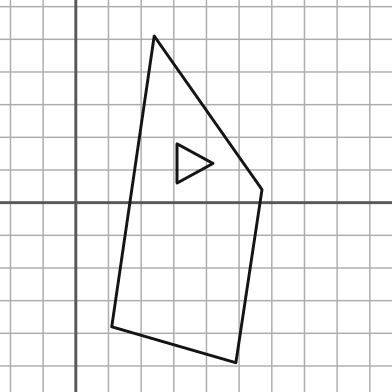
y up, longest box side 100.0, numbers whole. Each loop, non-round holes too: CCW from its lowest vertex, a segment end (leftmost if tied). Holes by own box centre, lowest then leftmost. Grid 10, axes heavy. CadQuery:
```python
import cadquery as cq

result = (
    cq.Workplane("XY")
    .moveTo(49.0, -49.0)
    .lineTo(57.0, 4.0)
    .lineTo(24.0, 51.0)
    .lineTo(11.0, -38.0)
    .close()
    .moveTo(31.0, 6.0)
    .lineTo(42.0, 12.0)
    .lineTo(31.0, 18.0)
    .close()
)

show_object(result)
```